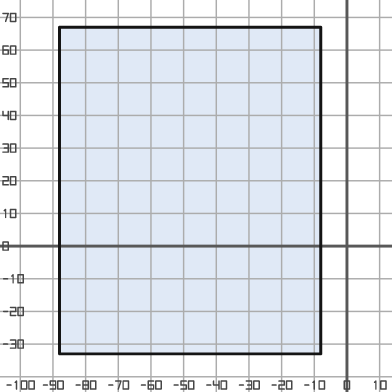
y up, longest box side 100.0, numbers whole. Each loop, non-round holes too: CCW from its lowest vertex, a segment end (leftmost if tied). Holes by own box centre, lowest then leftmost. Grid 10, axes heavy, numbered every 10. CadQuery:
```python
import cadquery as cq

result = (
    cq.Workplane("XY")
    .moveTo(-88.0, -33.0)
    .lineTo(-8.0, -33.0)
    .lineTo(-8.0, 67.0)
    .lineTo(-88.0, 67.0)
    .close()
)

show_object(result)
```